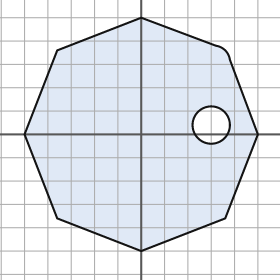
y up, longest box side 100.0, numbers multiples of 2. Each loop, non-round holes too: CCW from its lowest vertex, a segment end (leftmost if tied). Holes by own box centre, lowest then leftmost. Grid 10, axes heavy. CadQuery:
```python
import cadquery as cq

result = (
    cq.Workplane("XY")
    .moveTo(0.0, -50.0)
    .lineTo(36.0, -36.0)
    .lineTo(50.0, 0.0)
    .lineTo(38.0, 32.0)
    .threePointArc((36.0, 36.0), (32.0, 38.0))
    .lineTo(0.0, 50.0)
    .lineTo(-36.0, 36.0)
    .lineTo(-50.0, 0.0)
    .lineTo(-36.0, -36.0)
    .close()
    .moveTo(30.0, 4.0)
    .circle(8.0)
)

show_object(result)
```